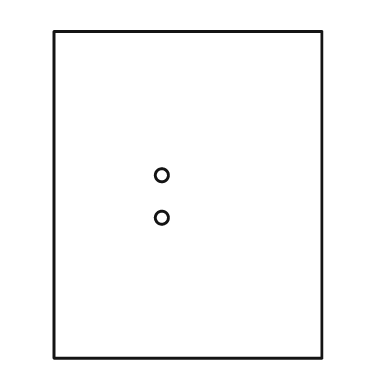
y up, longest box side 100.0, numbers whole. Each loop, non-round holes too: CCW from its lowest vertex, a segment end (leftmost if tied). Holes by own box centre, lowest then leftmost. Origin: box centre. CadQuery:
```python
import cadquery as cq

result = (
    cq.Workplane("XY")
    .moveTo(-41.0, -50.0)
    .lineTo(41.0, -50.0)
    .lineTo(41.0, 50.0)
    .lineTo(-41.0, 50.0)
    .close()
    .moveTo(-8.0, -7.0)
    .circle(2.0)
    .moveTo(-8.0, 6.0)
    .circle(2.0)
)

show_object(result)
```